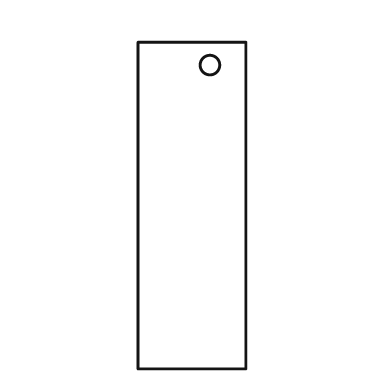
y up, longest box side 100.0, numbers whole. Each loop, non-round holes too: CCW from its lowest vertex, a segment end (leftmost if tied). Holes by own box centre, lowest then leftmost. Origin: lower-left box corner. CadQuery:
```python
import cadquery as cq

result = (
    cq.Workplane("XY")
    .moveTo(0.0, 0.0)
    .lineTo(33.0, 0.0)
    .lineTo(33.0, 100.0)
    .lineTo(0.0, 100.0)
    .close()
    .moveTo(22.0, 93.0)
    .circle(3.0)
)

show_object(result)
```